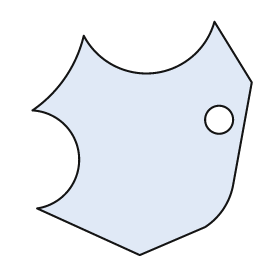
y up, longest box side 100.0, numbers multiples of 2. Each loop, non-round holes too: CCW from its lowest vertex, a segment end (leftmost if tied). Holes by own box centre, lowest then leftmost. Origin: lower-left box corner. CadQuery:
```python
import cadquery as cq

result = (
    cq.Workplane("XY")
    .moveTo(46.0, 0.0)
    .lineTo(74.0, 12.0)
    .threePointArc((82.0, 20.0), (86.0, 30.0))
    .lineTo(94.0, 74.0)
    .lineTo(78.0, 100.0)
    .threePointArc((52.0, 78.0), (22.0, 94.0))
    .threePointArc((14.0, 76.0), (0.0, 62.0))
    .threePointArc((20.0, 42.0), (2.0, 20.0))
    .close()
    .moveTo(80.0, 58.0)
    .circle(6.0)
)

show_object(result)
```